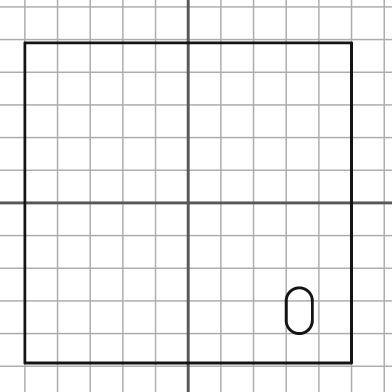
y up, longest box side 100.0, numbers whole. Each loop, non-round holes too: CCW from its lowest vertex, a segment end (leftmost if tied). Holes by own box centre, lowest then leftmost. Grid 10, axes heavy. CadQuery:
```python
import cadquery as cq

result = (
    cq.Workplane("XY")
    .moveTo(-50.0, -49.0)
    .lineTo(50.0, -49.0)
    .lineTo(50.0, 49.0)
    .lineTo(-50.0, 49.0)
    .close()
    .moveTo(30.0, -36.0)
    .threePointArc((34.0, -40.0), (38.0, -36.0))
    .lineTo(38.0, -30.0)
    .threePointArc((34.0, -26.0), (30.0, -30.0))
    .close()
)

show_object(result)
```